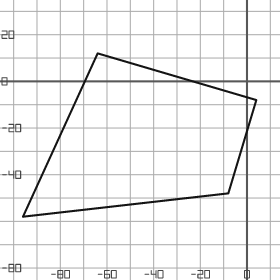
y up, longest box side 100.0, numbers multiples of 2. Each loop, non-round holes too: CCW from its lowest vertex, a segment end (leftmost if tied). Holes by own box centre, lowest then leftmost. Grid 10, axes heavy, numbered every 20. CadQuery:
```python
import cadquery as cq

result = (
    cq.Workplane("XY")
    .moveTo(-96.0, -58.0)
    .lineTo(-8.0, -48.0)
    .lineTo(4.0, -8.0)
    .lineTo(-64.0, 12.0)
    .close()
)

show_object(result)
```